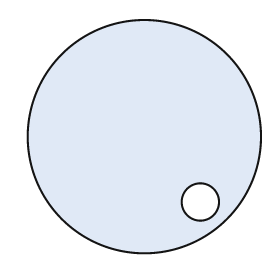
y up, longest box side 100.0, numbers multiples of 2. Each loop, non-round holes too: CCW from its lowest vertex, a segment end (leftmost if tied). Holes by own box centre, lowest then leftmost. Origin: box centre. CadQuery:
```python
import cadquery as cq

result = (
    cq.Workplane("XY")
    .moveTo(0.0, 0.0)
    .circle(50.0)
    .moveTo(24.0, -28.0)
    .circle(8.0)
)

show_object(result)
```